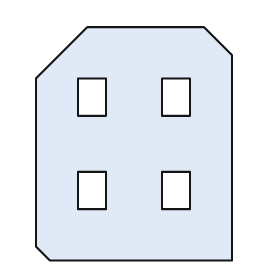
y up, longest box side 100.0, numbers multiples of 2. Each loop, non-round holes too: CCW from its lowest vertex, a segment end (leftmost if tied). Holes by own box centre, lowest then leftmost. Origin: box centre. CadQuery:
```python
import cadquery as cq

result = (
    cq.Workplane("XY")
    .moveTo(-36.0, -50.0)
    .lineTo(42.0, -50.0)
    .lineTo(42.0, 38.0)
    .lineTo(30.0, 50.0)
    .lineTo(-20.0, 50.0)
    .lineTo(-42.0, 28.0)
    .lineTo(-42.0, -44.0)
    .close()
    .moveTo(-24.0, -28.0)
    .lineTo(-12.0, -28.0)
    .lineTo(-12.0, -12.0)
    .lineTo(-24.0, -12.0)
    .close()
    .moveTo(12.0, -28.0)
    .lineTo(24.0, -28.0)
    .lineTo(24.0, -12.0)
    .lineTo(12.0, -12.0)
    .close()
    .moveTo(-24.0, 12.0)
    .lineTo(-12.0, 12.0)
    .lineTo(-12.0, 28.0)
    .lineTo(-24.0, 28.0)
    .close()
    .moveTo(12.0, 12.0)
    .lineTo(24.0, 12.0)
    .lineTo(24.0, 28.0)
    .lineTo(12.0, 28.0)
    .close()
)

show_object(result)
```